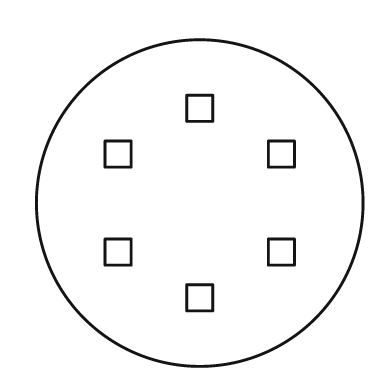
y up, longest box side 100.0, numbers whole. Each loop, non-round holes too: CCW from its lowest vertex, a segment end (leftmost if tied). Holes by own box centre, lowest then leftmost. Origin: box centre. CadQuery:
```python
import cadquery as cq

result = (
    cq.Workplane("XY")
    .moveTo(0.0, 0.0)
    .circle(50.0)
    .moveTo(-4.0, -33.0)
    .lineTo(4.0, -33.0)
    .lineTo(4.0, -25.0)
    .lineTo(-4.0, -25.0)
    .close()
    .moveTo(-29.0, -19.0)
    .lineTo(-21.0, -19.0)
    .lineTo(-21.0, -11.0)
    .lineTo(-29.0, -11.0)
    .close()
    .moveTo(21.0, -19.0)
    .lineTo(29.0, -19.0)
    .lineTo(29.0, -11.0)
    .lineTo(21.0, -11.0)
    .close()
    .moveTo(-29.0, 11.0)
    .lineTo(-21.0, 11.0)
    .lineTo(-21.0, 19.0)
    .lineTo(-29.0, 19.0)
    .close()
    .moveTo(21.0, 11.0)
    .lineTo(29.0, 11.0)
    .lineTo(29.0, 19.0)
    .lineTo(21.0, 19.0)
    .close()
    .moveTo(-4.0, 25.0)
    .lineTo(4.0, 25.0)
    .lineTo(4.0, 33.0)
    .lineTo(-4.0, 33.0)
    .close()
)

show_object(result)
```